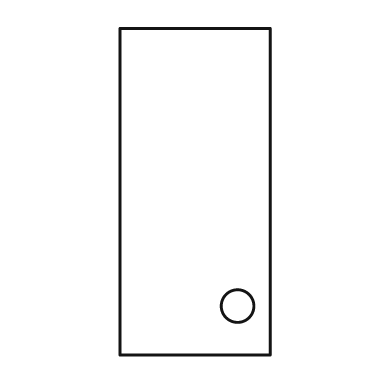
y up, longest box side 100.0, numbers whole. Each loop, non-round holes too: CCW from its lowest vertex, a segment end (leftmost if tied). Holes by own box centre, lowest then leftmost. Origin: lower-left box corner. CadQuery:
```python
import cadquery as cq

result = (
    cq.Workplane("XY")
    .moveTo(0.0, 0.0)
    .lineTo(46.0, 0.0)
    .lineTo(46.0, 100.0)
    .lineTo(0.0, 100.0)
    .close()
    .moveTo(36.0, 15.0)
    .circle(5.0)
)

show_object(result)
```